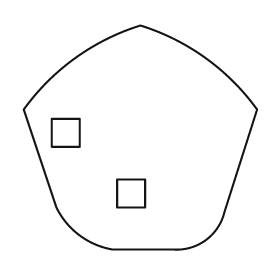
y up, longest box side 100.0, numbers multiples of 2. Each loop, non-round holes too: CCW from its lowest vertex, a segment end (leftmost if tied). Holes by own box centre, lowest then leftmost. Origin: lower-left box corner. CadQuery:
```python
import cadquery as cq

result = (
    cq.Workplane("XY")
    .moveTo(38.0, 0.0)
    .lineTo(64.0, 0.0)
    .threePointArc((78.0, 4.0), (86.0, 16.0))
    .lineTo(100.0, 60.0)
    .threePointArc((78.0, 82.0), (50.0, 96.0))
    .threePointArc((22.0, 82.0), (0.0, 60.0))
    .lineTo(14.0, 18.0)
    .threePointArc((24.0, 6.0), (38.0, 0.0))
    .close()
    .moveTo(40.0, 18.0)
    .lineTo(52.0, 18.0)
    .lineTo(52.0, 30.0)
    .lineTo(40.0, 30.0)
    .close()
    .moveTo(12.0, 44.0)
    .lineTo(24.0, 44.0)
    .lineTo(24.0, 56.0)
    .lineTo(12.0, 56.0)
    .close()
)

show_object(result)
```